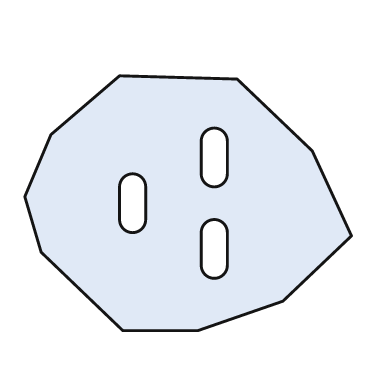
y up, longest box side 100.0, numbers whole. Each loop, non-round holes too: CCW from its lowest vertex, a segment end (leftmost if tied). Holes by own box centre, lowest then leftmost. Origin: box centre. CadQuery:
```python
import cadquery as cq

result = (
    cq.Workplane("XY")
    .moveTo(-20.0, -39.0)
    .lineTo(3.0, -39.0)
    .lineTo(29.0, -30.0)
    .lineTo(50.0, -10.0)
    .lineTo(38.0, 16.0)
    .lineTo(15.0, 38.0)
    .lineTo(-21.0, 39.0)
    .lineTo(-42.0, 21.0)
    .lineTo(-50.0, 2.0)
    .lineTo(-45.0, -15.0)
    .close()
    .moveTo(4.0, -19.0)
    .threePointArc((8.0, -23.0), (12.0, -19.0))
    .lineTo(12.0, -9.0)
    .threePointArc((8.0, -5.0), (4.0, -9.0))
    .close()
    .moveTo(-21.0, -5.0)
    .threePointArc((-17.0, -9.0), (-13.0, -5.0))
    .lineTo(-13.0, 5.0)
    .threePointArc((-17.0, 9.0), (-21.0, 5.0))
    .close()
    .moveTo(4.0, 9.0)
    .threePointArc((8.0, 5.0), (12.0, 9.0))
    .lineTo(12.0, 19.0)
    .threePointArc((8.0, 23.0), (4.0, 19.0))
    .close()
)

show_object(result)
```